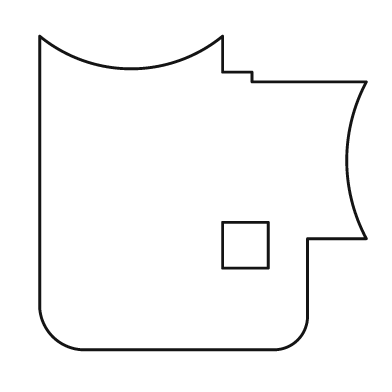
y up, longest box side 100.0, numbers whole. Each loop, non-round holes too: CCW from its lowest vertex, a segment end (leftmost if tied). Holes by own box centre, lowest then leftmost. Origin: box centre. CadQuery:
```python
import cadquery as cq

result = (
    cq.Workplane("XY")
    .moveTo(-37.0, -48.0)
    .lineTo(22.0, -48.0)
    .threePointArc((29.0, -45.0), (32.0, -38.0))
    .lineTo(32.0, -14.0)
    .lineTo(50.0, -14.0)
    .threePointArc((44.0, 10.0), (50.0, 34.0))
    .lineTo(15.0, 34.0)
    .lineTo(15.0, 37.0)
    .lineTo(6.0, 37.0)
    .lineTo(6.0, 48.0)
    .threePointArc((-22.0, 38.0), (-50.0, 48.0))
    .lineTo(-50.0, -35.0)
    .threePointArc((-46.0, -44.0), (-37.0, -48.0))
    .close()
    .moveTo(6.0, -23.0)
    .lineTo(20.0, -23.0)
    .lineTo(20.0, -9.0)
    .lineTo(6.0, -9.0)
    .close()
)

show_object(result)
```